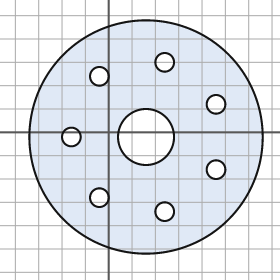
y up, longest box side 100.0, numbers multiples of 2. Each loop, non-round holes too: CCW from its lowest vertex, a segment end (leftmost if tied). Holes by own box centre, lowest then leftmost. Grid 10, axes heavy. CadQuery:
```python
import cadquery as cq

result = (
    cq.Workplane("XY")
    .moveTo(16.0, -2.0)
    .circle(50.0)
    .moveTo(24.0, -34.0)
    .circle(4.0)
    .moveTo(-4.0, -28.0)
    .circle(4.0)
    .moveTo(46.0, -16.0)
    .circle(4.0)
    .moveTo(-16.0, -2.0)
    .circle(4.0)
    .moveTo(16.0, -2.0)
    .circle(12.0)
    .moveTo(46.0, 12.0)
    .circle(4.0)
    .moveTo(-4.0, 24.0)
    .circle(4.0)
    .moveTo(24.0, 30.0)
    .circle(4.0)
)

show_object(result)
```